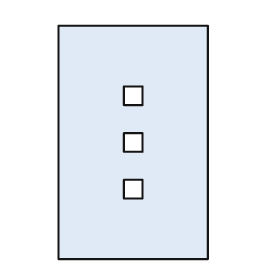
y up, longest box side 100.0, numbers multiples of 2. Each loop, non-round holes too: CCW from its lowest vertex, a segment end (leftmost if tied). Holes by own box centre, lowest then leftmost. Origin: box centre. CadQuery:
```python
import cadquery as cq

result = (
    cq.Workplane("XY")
    .moveTo(-32.0, -50.0)
    .lineTo(32.0, -50.0)
    .lineTo(32.0, 50.0)
    .lineTo(-32.0, 50.0)
    .close()
    .moveTo(-4.0, -24.0)
    .lineTo(4.0, -24.0)
    .lineTo(4.0, -16.0)
    .lineTo(-4.0, -16.0)
    .close()
    .moveTo(-4.0, -4.0)
    .lineTo(4.0, -4.0)
    .lineTo(4.0, 4.0)
    .lineTo(-4.0, 4.0)
    .close()
    .moveTo(-4.0, 16.0)
    .lineTo(4.0, 16.0)
    .lineTo(4.0, 24.0)
    .lineTo(-4.0, 24.0)
    .close()
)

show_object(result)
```